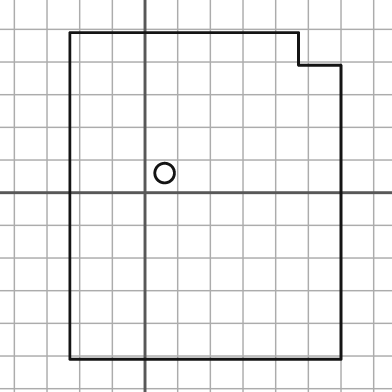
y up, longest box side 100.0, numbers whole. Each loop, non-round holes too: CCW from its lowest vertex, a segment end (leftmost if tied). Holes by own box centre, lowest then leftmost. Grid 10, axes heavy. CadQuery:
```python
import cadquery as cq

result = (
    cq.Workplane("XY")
    .moveTo(-23.0, -51.0)
    .lineTo(60.0, -51.0)
    .lineTo(60.0, 39.0)
    .lineTo(47.0, 39.0)
    .lineTo(47.0, 49.0)
    .lineTo(-23.0, 49.0)
    .close()
    .moveTo(6.0, 6.0)
    .circle(3.0)
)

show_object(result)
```